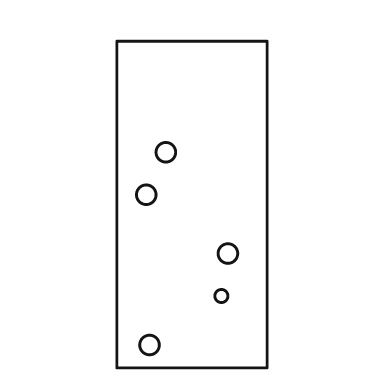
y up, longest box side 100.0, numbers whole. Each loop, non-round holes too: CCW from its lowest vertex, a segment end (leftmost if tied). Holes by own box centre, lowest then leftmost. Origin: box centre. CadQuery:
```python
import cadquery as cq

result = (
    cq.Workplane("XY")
    .moveTo(-23.0, -50.0)
    .lineTo(23.0, -50.0)
    .lineTo(23.0, 50.0)
    .lineTo(-23.0, 50.0)
    .close()
    .moveTo(-13.0, -43.0)
    .circle(3.0)
    .moveTo(9.0, -28.0)
    .circle(2.0)
    .moveTo(11.0, -15.0)
    .circle(3.0)
    .moveTo(-14.0, 3.0)
    .circle(3.0)
    .moveTo(-8.0, 16.0)
    .circle(3.0)
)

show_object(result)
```